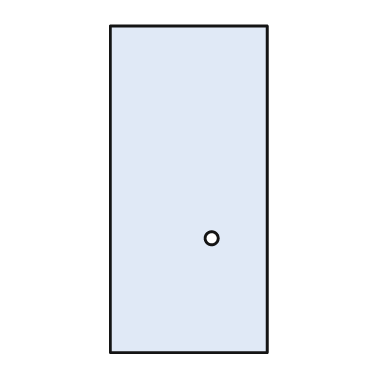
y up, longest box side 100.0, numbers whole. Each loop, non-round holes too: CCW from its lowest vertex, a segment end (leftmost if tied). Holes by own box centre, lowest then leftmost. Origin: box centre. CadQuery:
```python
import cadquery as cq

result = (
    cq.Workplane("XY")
    .moveTo(-24.0, -50.0)
    .lineTo(24.0, -50.0)
    .lineTo(24.0, 50.0)
    .lineTo(-24.0, 50.0)
    .close()
    .moveTo(7.0, -15.0)
    .circle(2.0)
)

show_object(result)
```